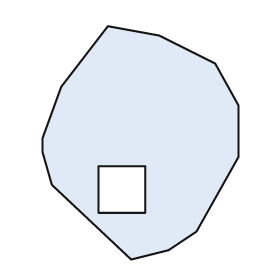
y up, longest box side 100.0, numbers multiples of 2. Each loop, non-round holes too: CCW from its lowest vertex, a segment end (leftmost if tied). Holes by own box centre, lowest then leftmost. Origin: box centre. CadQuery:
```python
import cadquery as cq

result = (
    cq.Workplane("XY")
    .moveTo(-4.0, -50.0)
    .lineTo(12.0, -46.0)
    .lineTo(24.0, -38.0)
    .lineTo(42.0, -6.0)
    .lineTo(42.0, 16.0)
    .lineTo(32.0, 34.0)
    .lineTo(8.0, 46.0)
    .lineTo(-14.0, 50.0)
    .lineTo(-34.0, 24.0)
    .lineTo(-42.0, 2.0)
    .lineTo(-42.0, -4.0)
    .lineTo(-38.0, -18.0)
    .close()
    .moveTo(-18.0, -30.0)
    .lineTo(2.0, -30.0)
    .lineTo(2.0, -10.0)
    .lineTo(-18.0, -10.0)
    .close()
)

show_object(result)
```